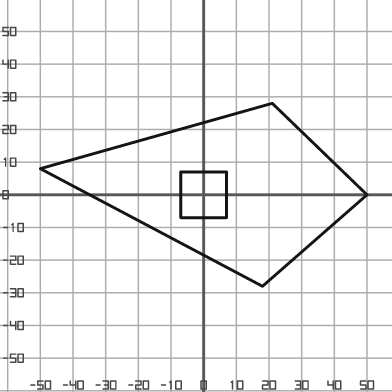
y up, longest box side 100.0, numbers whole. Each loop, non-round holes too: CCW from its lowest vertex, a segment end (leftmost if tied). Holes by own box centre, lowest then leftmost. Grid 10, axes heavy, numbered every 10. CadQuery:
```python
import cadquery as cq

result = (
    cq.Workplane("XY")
    .moveTo(18.0, -28.0)
    .lineTo(50.0, 0.0)
    .lineTo(21.0, 28.0)
    .lineTo(-50.0, 8.0)
    .close()
    .moveTo(-7.0, -7.0)
    .lineTo(7.0, -7.0)
    .lineTo(7.0, 7.0)
    .lineTo(-7.0, 7.0)
    .close()
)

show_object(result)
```